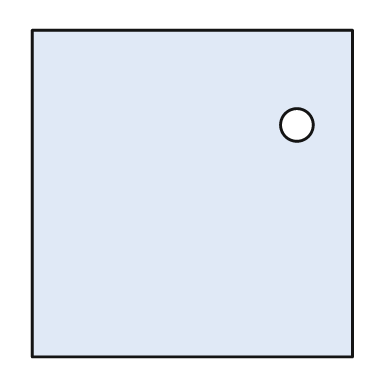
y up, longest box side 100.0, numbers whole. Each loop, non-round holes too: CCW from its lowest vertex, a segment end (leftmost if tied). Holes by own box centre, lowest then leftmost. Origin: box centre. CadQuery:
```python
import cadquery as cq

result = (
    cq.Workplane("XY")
    .moveTo(-49.0, -50.0)
    .lineTo(49.0, -50.0)
    .lineTo(49.0, 50.0)
    .lineTo(-49.0, 50.0)
    .close()
    .moveTo(32.0, 21.0)
    .circle(5.0)
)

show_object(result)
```